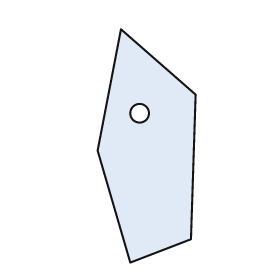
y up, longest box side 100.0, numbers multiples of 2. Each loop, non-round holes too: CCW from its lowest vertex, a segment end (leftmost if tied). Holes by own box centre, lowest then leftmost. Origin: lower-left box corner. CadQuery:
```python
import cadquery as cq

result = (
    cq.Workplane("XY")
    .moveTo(14.0, 0.0)
    .lineTo(40.0, 10.0)
    .lineTo(42.0, 72.0)
    .lineTo(10.0, 100.0)
    .lineTo(0.0, 48.0)
    .close()
    .moveTo(18.0, 64.0)
    .circle(4.0)
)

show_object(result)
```